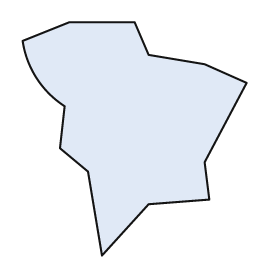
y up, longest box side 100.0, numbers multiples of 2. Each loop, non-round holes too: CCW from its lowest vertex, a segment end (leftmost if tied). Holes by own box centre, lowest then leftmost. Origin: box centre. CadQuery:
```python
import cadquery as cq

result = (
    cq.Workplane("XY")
    .moveTo(-14.0, -50.0)
    .lineTo(6.0, -28.0)
    .lineTo(32.0, -26.0)
    .lineTo(30.0, -10.0)
    .lineTo(48.0, 24.0)
    .lineTo(30.0, 32.0)
    .lineTo(6.0, 36.0)
    .lineTo(0.0, 50.0)
    .lineTo(-28.0, 50.0)
    .lineTo(-48.0, 42.0)
    .threePointArc((-42.0, 26.0), (-30.0, 14.0))
    .lineTo(-32.0, -4.0)
    .lineTo(-20.0, -14.0)
    .close()
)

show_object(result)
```